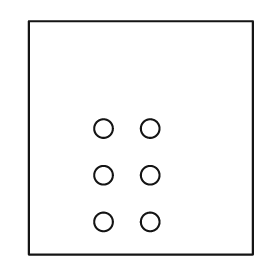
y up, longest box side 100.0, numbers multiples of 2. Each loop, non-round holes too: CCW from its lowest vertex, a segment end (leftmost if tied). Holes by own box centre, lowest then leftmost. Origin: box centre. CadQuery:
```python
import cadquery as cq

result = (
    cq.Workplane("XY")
    .moveTo(-48.0, -50.0)
    .lineTo(48.0, -50.0)
    .lineTo(48.0, 50.0)
    .lineTo(-48.0, 50.0)
    .close()
    .moveTo(-16.0, -36.0)
    .circle(4.0)
    .moveTo(4.0, -36.0)
    .circle(4.0)
    .moveTo(-16.0, -16.0)
    .circle(4.0)
    .moveTo(4.0, -16.0)
    .circle(4.0)
    .moveTo(-16.0, 4.0)
    .circle(4.0)
    .moveTo(4.0, 4.0)
    .circle(4.0)
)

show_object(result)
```